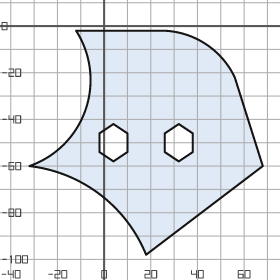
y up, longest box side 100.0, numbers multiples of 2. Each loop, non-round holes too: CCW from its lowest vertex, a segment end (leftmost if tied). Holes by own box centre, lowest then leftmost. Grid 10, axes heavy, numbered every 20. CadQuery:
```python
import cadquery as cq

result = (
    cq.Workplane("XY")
    .moveTo(18.0, -98.0)
    .lineTo(68.0, -60.0)
    .lineTo(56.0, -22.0)
    .threePointArc((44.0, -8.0), (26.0, -2.0))
    .lineTo(-12.0, -2.0)
    .threePointArc((-8.0, -36.0), (-32.0, -60.0))
    .threePointArc((-2.0, -72.0), (18.0, -98.0))
    .close()
    .moveTo(4.0, -58.0)
    .lineTo(10.0, -54.0)
    .lineTo(10.0, -46.0)
    .lineTo(4.0, -42.0)
    .lineTo(-2.0, -46.0)
    .lineTo(-2.0, -54.0)
    .close()
    .moveTo(32.0, -58.0)
    .lineTo(38.0, -54.0)
    .lineTo(38.0, -46.0)
    .lineTo(32.0, -42.0)
    .lineTo(26.0, -46.0)
    .lineTo(26.0, -54.0)
    .close()
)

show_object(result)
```